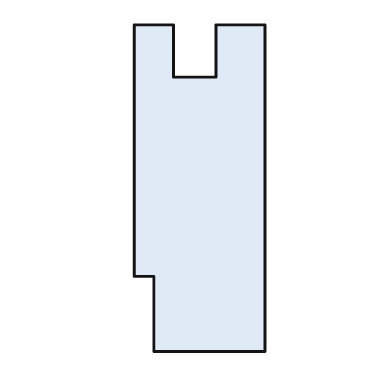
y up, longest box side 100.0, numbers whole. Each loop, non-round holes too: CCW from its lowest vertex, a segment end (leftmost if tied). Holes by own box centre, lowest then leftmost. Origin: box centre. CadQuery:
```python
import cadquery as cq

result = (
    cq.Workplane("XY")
    .moveTo(-14.0, -50.0)
    .lineTo(20.0, -50.0)
    .lineTo(20.0, 50.0)
    .lineTo(5.0, 50.0)
    .lineTo(5.0, 34.0)
    .lineTo(-8.0, 34.0)
    .lineTo(-8.0, 50.0)
    .lineTo(-20.0, 50.0)
    .lineTo(-20.0, -27.0)
    .lineTo(-14.0, -27.0)
    .close()
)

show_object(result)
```